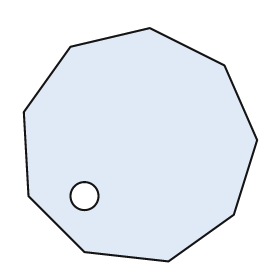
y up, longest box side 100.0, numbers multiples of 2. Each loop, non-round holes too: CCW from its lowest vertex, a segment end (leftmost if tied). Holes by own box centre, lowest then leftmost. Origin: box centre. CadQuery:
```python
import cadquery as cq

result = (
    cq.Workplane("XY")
    .moveTo(12.0, -50.0)
    .lineTo(40.0, -30.0)
    .lineTo(50.0, 2.0)
    .lineTo(36.0, 34.0)
    .lineTo(4.0, 50.0)
    .lineTo(-30.0, 42.0)
    .lineTo(-50.0, 14.0)
    .lineTo(-48.0, -22.0)
    .lineTo(-24.0, -46.0)
    .close()
    .moveTo(-24.0, -22.0)
    .circle(6.0)
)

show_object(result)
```